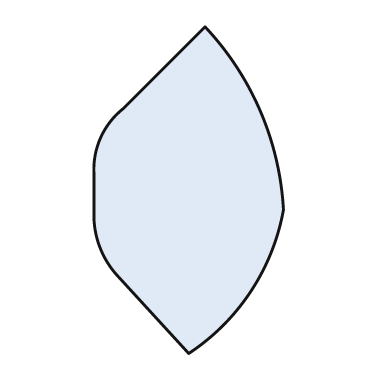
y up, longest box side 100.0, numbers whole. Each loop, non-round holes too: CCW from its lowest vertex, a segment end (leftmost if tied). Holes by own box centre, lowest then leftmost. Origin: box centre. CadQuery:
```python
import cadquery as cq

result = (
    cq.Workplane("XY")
    .moveTo(0.0, -50.0)
    .threePointArc((19.0, -31.0), (29.0, -6.0))
    .threePointArc((22.0, 24.0), (5.0, 50.0))
    .lineTo(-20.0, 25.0)
    .threePointArc((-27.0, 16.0), (-29.0, 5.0))
    .lineTo(-29.0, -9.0)
    .threePointArc((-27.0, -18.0), (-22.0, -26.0))
    .close()
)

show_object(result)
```